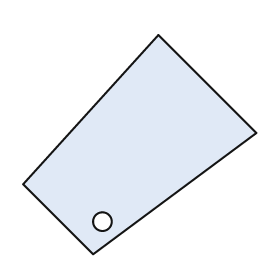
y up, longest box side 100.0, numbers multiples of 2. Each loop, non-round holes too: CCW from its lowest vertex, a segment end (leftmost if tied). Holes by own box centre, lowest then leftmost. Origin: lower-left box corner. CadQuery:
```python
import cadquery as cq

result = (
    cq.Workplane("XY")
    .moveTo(30.0, 0.0)
    .lineTo(100.0, 52.0)
    .lineTo(58.0, 94.0)
    .lineTo(0.0, 30.0)
    .close()
    .moveTo(34.0, 14.0)
    .circle(4.0)
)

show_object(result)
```